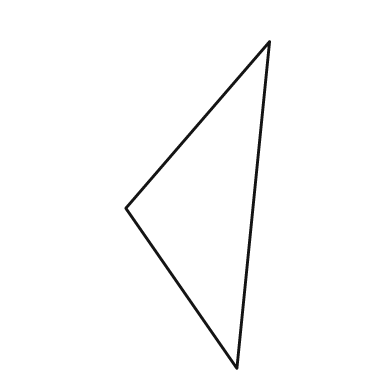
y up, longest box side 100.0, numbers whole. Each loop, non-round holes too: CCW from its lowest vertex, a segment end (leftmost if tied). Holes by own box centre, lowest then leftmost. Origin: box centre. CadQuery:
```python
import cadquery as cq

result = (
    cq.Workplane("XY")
    .moveTo(12.0, -50.0)
    .lineTo(22.0, 50.0)
    .lineTo(-22.0, -1.0)
    .close()
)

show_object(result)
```